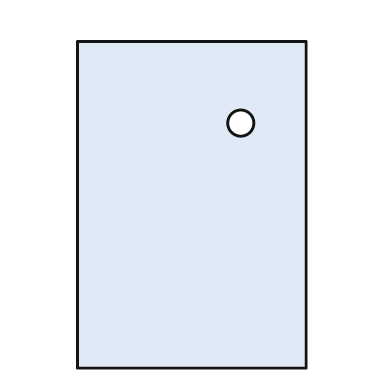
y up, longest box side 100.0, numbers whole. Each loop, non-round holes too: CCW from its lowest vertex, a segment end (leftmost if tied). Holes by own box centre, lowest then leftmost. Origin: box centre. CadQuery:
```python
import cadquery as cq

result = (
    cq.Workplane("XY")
    .moveTo(-35.0, -50.0)
    .lineTo(35.0, -50.0)
    .lineTo(35.0, 50.0)
    .lineTo(-35.0, 50.0)
    .close()
    .moveTo(15.0, 25.0)
    .circle(4.0)
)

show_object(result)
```